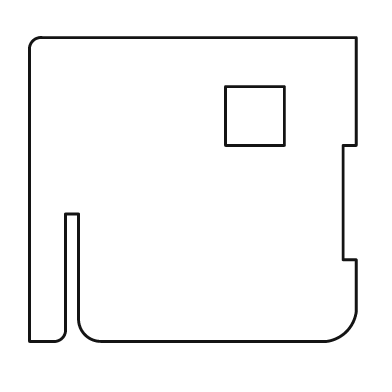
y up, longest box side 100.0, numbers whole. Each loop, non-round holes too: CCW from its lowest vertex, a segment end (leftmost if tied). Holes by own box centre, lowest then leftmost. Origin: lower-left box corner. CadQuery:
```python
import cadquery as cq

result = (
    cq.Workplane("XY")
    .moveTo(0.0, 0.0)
    .lineTo(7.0, 0.0)
    .threePointArc((10.0, 1.0), (11.0, 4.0))
    .lineTo(11.0, 39.0)
    .lineTo(15.0, 39.0)
    .lineTo(15.0, 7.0)
    .threePointArc((17.0, 2.0), (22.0, 0.0))
    .lineTo(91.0, 0.0)
    .threePointArc((97.0, 3.0), (100.0, 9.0))
    .lineTo(100.0, 25.0)
    .lineTo(96.0, 25.0)
    .lineTo(96.0, 60.0)
    .lineTo(100.0, 60.0)
    .lineTo(100.0, 93.0)
    .lineTo(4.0, 93.0)
    .threePointArc((1.0, 92.0), (0.0, 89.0))
    .close()
    .moveTo(60.0, 60.0)
    .lineTo(78.0, 60.0)
    .lineTo(78.0, 78.0)
    .lineTo(60.0, 78.0)
    .close()
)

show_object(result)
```